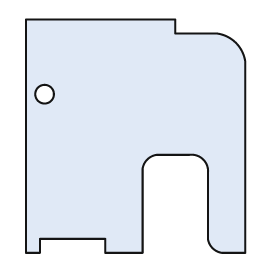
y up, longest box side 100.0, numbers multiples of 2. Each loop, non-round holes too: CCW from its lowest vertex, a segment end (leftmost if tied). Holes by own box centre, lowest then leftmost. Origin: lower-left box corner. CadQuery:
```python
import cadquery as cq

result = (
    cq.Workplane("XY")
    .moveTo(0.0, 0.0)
    .lineTo(6.0, 0.0)
    .lineTo(6.0, 6.0)
    .lineTo(34.0, 6.0)
    .lineTo(34.0, 0.0)
    .lineTo(50.0, 0.0)
    .lineTo(50.0, 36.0)
    .threePointArc((52.0, 40.0), (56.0, 42.0))
    .lineTo(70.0, 42.0)
    .threePointArc((76.0, 40.0), (78.0, 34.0))
    .lineTo(78.0, 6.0)
    .threePointArc((80.0, 2.0), (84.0, 0.0))
    .lineTo(94.0, 0.0)
    .lineTo(94.0, 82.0)
    .threePointArc((90.0, 90.0), (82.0, 94.0))
    .lineTo(64.0, 94.0)
    .lineTo(64.0, 100.0)
    .lineTo(0.0, 100.0)
    .close()
    .moveTo(8.0, 68.0)
    .circle(4.0)
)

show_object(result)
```